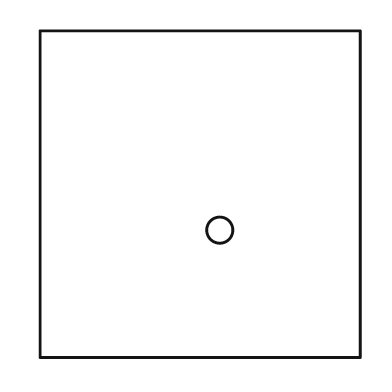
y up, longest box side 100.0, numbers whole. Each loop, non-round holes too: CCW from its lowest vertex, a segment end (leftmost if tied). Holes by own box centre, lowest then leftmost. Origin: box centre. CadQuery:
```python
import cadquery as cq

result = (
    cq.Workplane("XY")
    .moveTo(-49.0, -50.0)
    .lineTo(49.0, -50.0)
    .lineTo(49.0, 50.0)
    .lineTo(-49.0, 50.0)
    .close()
    .moveTo(6.0, -11.0)
    .circle(4.0)
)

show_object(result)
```